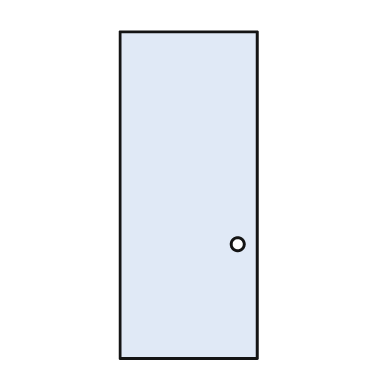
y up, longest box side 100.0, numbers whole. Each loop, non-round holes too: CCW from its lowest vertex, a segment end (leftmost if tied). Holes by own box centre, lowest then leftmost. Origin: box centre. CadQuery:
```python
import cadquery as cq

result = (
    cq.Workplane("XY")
    .moveTo(-21.0, -50.0)
    .lineTo(21.0, -50.0)
    .lineTo(21.0, 50.0)
    .lineTo(-21.0, 50.0)
    .close()
    .moveTo(15.0, -15.0)
    .circle(2.0)
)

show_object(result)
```